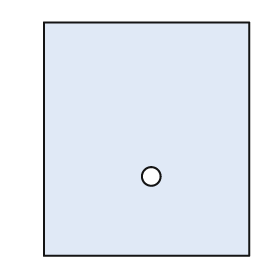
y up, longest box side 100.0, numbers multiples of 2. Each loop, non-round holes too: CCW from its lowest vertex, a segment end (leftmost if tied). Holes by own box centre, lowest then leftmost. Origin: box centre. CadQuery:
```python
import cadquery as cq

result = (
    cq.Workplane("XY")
    .moveTo(-44.0, -50.0)
    .lineTo(44.0, -50.0)
    .lineTo(44.0, 50.0)
    .lineTo(-44.0, 50.0)
    .close()
    .moveTo(2.0, -16.0)
    .circle(4.0)
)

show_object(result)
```